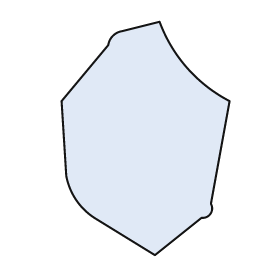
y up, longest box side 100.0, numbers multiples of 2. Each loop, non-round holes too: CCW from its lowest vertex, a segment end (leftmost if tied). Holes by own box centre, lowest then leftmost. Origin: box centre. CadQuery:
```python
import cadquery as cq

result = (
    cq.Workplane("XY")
    .moveTo(4.0, -50.0)
    .lineTo(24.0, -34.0)
    .threePointArc((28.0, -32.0), (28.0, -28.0))
    .lineTo(36.0, 16.0)
    .threePointArc((18.0, 30.0), (6.0, 50.0))
    .lineTo(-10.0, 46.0)
    .threePointArc((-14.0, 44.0), (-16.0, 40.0))
    .lineTo(-36.0, 16.0)
    .lineTo(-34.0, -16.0)
    .threePointArc((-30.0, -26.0), (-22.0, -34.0))
    .close()
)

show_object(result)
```